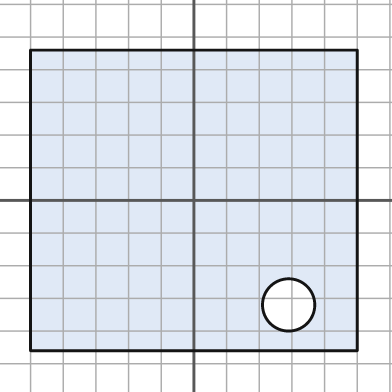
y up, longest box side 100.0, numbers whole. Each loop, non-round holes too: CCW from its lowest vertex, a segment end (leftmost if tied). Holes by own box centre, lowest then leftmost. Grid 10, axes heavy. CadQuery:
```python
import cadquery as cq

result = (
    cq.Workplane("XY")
    .moveTo(-50.0, -46.0)
    .lineTo(50.0, -46.0)
    .lineTo(50.0, 46.0)
    .lineTo(-50.0, 46.0)
    .close()
    .moveTo(29.0, -32.0)
    .circle(8.0)
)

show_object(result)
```